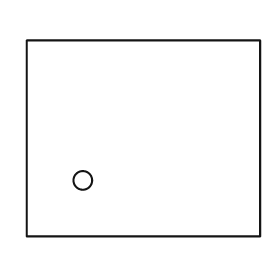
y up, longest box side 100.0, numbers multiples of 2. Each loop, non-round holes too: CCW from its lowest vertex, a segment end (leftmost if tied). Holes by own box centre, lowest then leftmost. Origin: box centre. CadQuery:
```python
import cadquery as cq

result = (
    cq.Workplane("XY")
    .moveTo(-50.0, -42.0)
    .lineTo(50.0, -42.0)
    .lineTo(50.0, 42.0)
    .lineTo(-50.0, 42.0)
    .close()
    .moveTo(-26.0, -18.0)
    .circle(4.0)
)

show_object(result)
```